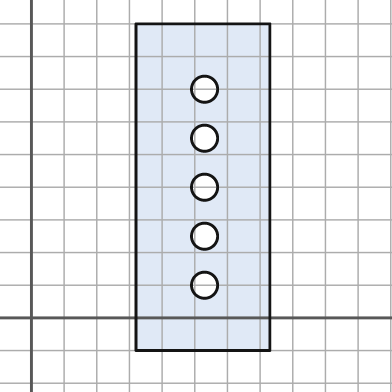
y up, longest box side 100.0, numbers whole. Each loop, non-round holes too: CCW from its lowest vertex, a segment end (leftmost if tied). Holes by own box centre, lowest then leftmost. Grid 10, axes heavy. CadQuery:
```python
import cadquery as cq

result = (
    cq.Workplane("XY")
    .moveTo(32.0, -10.0)
    .lineTo(73.0, -10.0)
    .lineTo(73.0, 90.0)
    .lineTo(32.0, 90.0)
    .close()
    .moveTo(53.0, 10.0)
    .circle(4.0)
    .moveTo(53.0, 25.0)
    .circle(4.0)
    .moveTo(53.0, 40.0)
    .circle(4.0)
    .moveTo(53.0, 55.0)
    .circle(4.0)
    .moveTo(53.0, 70.0)
    .circle(4.0)
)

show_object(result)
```